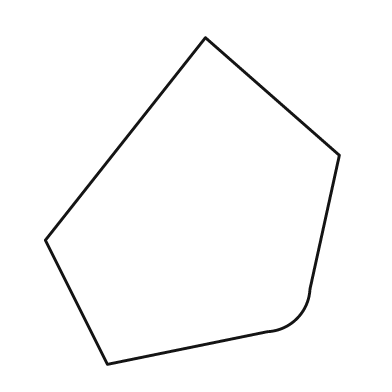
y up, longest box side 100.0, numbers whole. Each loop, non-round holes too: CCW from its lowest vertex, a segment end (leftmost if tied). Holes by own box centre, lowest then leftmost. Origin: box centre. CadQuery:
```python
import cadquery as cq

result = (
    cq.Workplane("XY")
    .moveTo(-26.0, -50.0)
    .lineTo(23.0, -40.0)
    .threePointArc((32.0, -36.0), (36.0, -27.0))
    .lineTo(45.0, 14.0)
    .lineTo(4.0, 50.0)
    .lineTo(-45.0, -12.0)
    .close()
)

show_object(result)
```